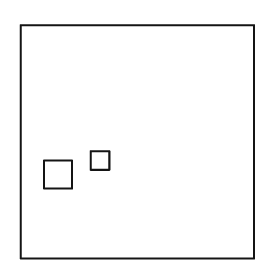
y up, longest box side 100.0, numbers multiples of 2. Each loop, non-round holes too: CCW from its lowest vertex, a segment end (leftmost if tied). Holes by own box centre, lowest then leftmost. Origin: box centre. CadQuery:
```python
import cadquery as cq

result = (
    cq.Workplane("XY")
    .moveTo(-50.0, -50.0)
    .lineTo(50.0, -50.0)
    .lineTo(50.0, 50.0)
    .lineTo(-50.0, 50.0)
    .close()
    .moveTo(-40.0, -20.0)
    .lineTo(-28.0, -20.0)
    .lineTo(-28.0, -8.0)
    .lineTo(-40.0, -8.0)
    .close()
    .moveTo(-20.0, -12.0)
    .lineTo(-12.0, -12.0)
    .lineTo(-12.0, -4.0)
    .lineTo(-20.0, -4.0)
    .close()
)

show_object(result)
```